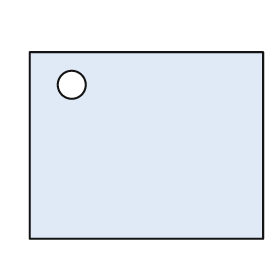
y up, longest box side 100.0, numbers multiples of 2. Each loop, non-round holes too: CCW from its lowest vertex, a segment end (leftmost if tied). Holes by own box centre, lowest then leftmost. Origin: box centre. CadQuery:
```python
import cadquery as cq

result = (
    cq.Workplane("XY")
    .moveTo(-50.0, -40.0)
    .lineTo(50.0, -40.0)
    .lineTo(50.0, 40.0)
    .lineTo(-50.0, 40.0)
    .close()
    .moveTo(-32.0, 26.0)
    .circle(6.0)
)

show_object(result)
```